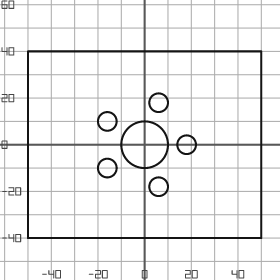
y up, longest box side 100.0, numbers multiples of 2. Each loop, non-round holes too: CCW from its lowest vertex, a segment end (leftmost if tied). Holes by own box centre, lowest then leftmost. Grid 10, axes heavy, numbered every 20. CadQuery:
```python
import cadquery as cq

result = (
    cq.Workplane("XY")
    .moveTo(-50.0, -40.0)
    .lineTo(50.0, -40.0)
    .lineTo(50.0, 40.0)
    .lineTo(-50.0, 40.0)
    .close()
    .moveTo(6.0, -18.0)
    .circle(4.0)
    .moveTo(-16.0, -10.0)
    .circle(4.0)
    .moveTo(0.0, 0.0)
    .circle(10.0)
    .moveTo(18.0, 0.0)
    .circle(4.0)
    .moveTo(-16.0, 10.0)
    .circle(4.0)
    .moveTo(6.0, 18.0)
    .circle(4.0)
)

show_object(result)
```